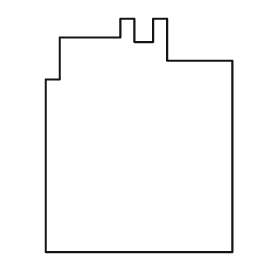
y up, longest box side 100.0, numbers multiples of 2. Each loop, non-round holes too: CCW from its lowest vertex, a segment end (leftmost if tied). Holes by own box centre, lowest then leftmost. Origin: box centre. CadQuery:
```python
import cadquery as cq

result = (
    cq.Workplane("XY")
    .moveTo(-40.0, -50.0)
    .lineTo(40.0, -50.0)
    .lineTo(40.0, 32.0)
    .lineTo(12.0, 32.0)
    .lineTo(12.0, 50.0)
    .lineTo(6.0, 50.0)
    .lineTo(6.0, 40.0)
    .lineTo(-2.0, 40.0)
    .lineTo(-2.0, 50.0)
    .lineTo(-8.0, 50.0)
    .lineTo(-8.0, 42.0)
    .lineTo(-34.0, 42.0)
    .lineTo(-34.0, 24.0)
    .lineTo(-40.0, 24.0)
    .close()
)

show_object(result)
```